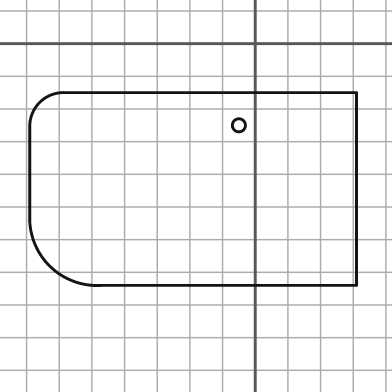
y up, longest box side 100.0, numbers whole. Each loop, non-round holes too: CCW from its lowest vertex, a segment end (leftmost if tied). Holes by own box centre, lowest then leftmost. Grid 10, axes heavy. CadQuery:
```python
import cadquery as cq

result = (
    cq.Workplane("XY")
    .moveTo(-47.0, -74.0)
    .lineTo(31.0, -74.0)
    .lineTo(31.0, -15.0)
    .lineTo(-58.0, -15.0)
    .threePointArc((-66.0, -18.0), (-69.0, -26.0))
    .lineTo(-69.0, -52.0)
    .threePointArc((-63.0, -68.0), (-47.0, -74.0))
    .close()
    .moveTo(-5.0, -25.0)
    .circle(2.0)
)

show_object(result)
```